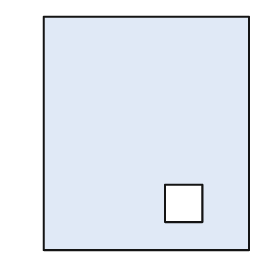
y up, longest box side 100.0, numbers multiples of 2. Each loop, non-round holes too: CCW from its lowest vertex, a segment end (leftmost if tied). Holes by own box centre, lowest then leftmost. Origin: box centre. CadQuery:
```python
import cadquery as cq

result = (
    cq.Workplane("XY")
    .moveTo(-44.0, -50.0)
    .lineTo(44.0, -50.0)
    .lineTo(44.0, 50.0)
    .lineTo(-44.0, 50.0)
    .close()
    .moveTo(8.0, -38.0)
    .lineTo(24.0, -38.0)
    .lineTo(24.0, -22.0)
    .lineTo(8.0, -22.0)
    .close()
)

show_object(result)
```